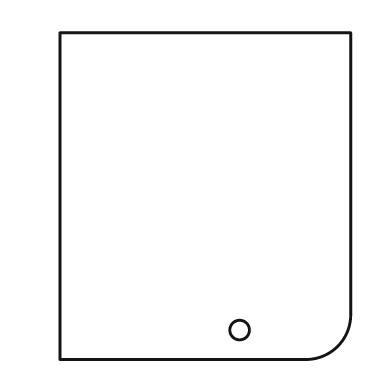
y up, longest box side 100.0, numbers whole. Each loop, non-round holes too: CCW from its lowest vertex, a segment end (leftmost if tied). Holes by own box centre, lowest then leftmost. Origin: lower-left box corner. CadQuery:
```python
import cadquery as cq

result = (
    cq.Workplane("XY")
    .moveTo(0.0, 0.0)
    .lineTo(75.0, 0.0)
    .threePointArc((85.0, 4.0), (89.0, 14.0))
    .lineTo(89.0, 100.0)
    .lineTo(0.0, 100.0)
    .close()
    .moveTo(55.0, 9.0)
    .circle(3.0)
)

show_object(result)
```